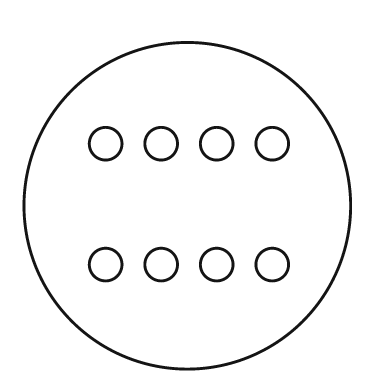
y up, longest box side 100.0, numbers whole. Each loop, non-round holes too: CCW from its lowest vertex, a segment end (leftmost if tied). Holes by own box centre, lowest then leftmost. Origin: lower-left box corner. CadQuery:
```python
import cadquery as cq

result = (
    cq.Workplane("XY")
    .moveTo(50.0, 50.0)
    .circle(50.0)
    .moveTo(25.0, 32.0)
    .circle(5.0)
    .moveTo(42.0, 32.0)
    .circle(5.0)
    .moveTo(59.0, 32.0)
    .circle(5.0)
    .moveTo(76.0, 32.0)
    .circle(5.0)
    .moveTo(25.0, 69.0)
    .circle(5.0)
    .moveTo(42.0, 69.0)
    .circle(5.0)
    .moveTo(59.0, 69.0)
    .circle(5.0)
    .moveTo(76.0, 69.0)
    .circle(5.0)
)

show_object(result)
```